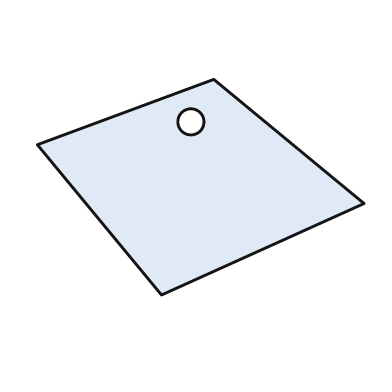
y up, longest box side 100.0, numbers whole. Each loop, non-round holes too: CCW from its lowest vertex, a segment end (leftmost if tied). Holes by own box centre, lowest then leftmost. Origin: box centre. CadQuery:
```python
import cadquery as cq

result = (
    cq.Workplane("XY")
    .moveTo(-12.0, -33.0)
    .lineTo(50.0, -5.0)
    .lineTo(4.0, 33.0)
    .lineTo(-50.0, 13.0)
    .close()
    .moveTo(-3.0, 20.0)
    .circle(4.0)
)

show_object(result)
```